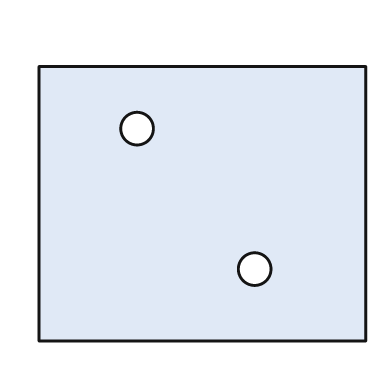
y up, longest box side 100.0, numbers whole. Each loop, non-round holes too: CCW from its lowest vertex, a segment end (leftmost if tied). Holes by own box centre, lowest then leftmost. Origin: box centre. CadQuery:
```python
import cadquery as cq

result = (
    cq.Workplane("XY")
    .moveTo(-50.0, -42.0)
    .lineTo(50.0, -42.0)
    .lineTo(50.0, 42.0)
    .lineTo(-50.0, 42.0)
    .close()
    .moveTo(16.0, -20.0)
    .circle(5.0)
    .moveTo(-20.0, 23.0)
    .circle(5.0)
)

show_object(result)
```